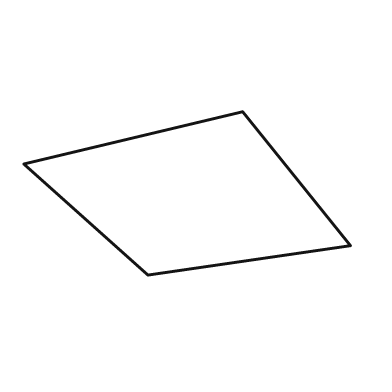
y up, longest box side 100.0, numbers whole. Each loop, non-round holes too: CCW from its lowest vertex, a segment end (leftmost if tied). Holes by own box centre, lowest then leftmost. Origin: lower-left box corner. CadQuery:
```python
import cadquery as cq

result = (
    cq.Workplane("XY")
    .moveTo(38.0, 0.0)
    .lineTo(100.0, 9.0)
    .lineTo(67.0, 50.0)
    .lineTo(0.0, 34.0)
    .close()
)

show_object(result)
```